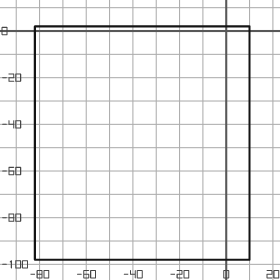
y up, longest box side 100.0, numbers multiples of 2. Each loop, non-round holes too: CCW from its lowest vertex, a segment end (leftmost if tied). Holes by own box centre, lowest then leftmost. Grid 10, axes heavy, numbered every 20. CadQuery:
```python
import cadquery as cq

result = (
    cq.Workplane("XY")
    .moveTo(-82.0, -98.0)
    .lineTo(10.0, -98.0)
    .lineTo(10.0, 2.0)
    .lineTo(-82.0, 2.0)
    .close()
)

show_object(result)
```